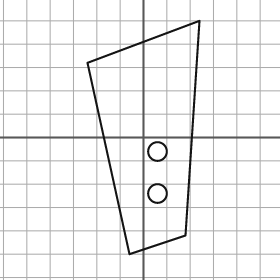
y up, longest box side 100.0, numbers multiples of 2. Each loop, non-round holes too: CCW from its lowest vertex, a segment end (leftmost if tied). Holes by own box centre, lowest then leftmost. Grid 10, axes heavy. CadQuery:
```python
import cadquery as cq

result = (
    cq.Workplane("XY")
    .moveTo(-6.0, -50.0)
    .lineTo(18.0, -42.0)
    .lineTo(24.0, 50.0)
    .lineTo(-24.0, 32.0)
    .close()
    .moveTo(6.0, -24.0)
    .circle(4.0)
    .moveTo(6.0, -6.0)
    .circle(4.0)
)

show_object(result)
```